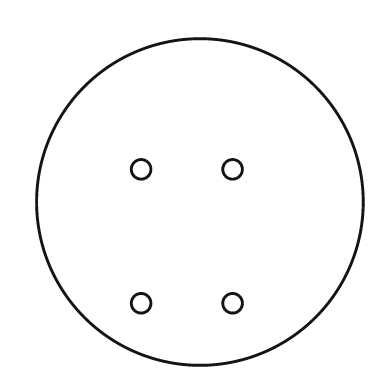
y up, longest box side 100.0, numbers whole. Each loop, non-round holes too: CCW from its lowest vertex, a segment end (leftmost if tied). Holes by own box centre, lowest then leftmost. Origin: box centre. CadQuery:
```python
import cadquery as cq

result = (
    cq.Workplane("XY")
    .moveTo(0.0, 0.0)
    .circle(50.0)
    .moveTo(-18.0, -31.0)
    .circle(3.0)
    .moveTo(10.0, -31.0)
    .circle(3.0)
    .moveTo(-18.0, 10.0)
    .circle(3.0)
    .moveTo(10.0, 10.0)
    .circle(3.0)
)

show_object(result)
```